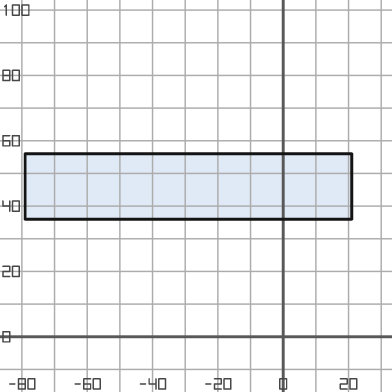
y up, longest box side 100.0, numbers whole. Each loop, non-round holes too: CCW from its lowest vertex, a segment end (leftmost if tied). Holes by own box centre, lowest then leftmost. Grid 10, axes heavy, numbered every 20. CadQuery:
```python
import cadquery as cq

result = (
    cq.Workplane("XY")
    .moveTo(-79.0, 36.0)
    .lineTo(21.0, 36.0)
    .lineTo(21.0, 56.0)
    .lineTo(-79.0, 56.0)
    .close()
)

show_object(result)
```